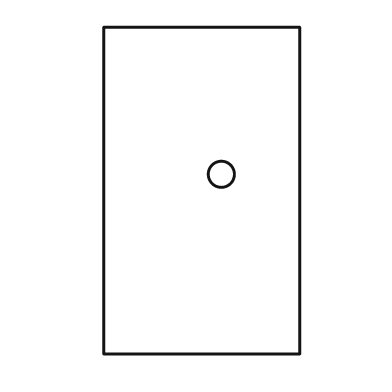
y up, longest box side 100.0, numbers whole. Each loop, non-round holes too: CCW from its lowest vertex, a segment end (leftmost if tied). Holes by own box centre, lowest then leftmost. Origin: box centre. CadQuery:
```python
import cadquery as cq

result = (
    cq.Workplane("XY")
    .moveTo(-30.0, -50.0)
    .lineTo(30.0, -50.0)
    .lineTo(30.0, 50.0)
    .lineTo(-30.0, 50.0)
    .close()
    .moveTo(6.0, 5.0)
    .circle(4.0)
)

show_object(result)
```